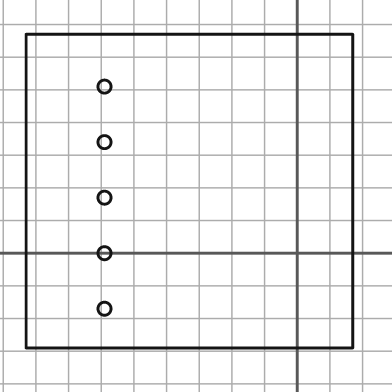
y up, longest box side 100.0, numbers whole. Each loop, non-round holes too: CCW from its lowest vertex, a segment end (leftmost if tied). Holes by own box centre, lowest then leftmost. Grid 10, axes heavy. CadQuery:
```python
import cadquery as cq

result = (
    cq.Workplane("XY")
    .moveTo(-83.0, -29.0)
    .lineTo(17.0, -29.0)
    .lineTo(17.0, 67.0)
    .lineTo(-83.0, 67.0)
    .close()
    .moveTo(-59.0, -17.0)
    .circle(2.0)
    .moveTo(-59.0, 0.0)
    .circle(2.0)
    .moveTo(-59.0, 17.0)
    .circle(2.0)
    .moveTo(-59.0, 34.0)
    .circle(2.0)
    .moveTo(-59.0, 51.0)
    .circle(2.0)
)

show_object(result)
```